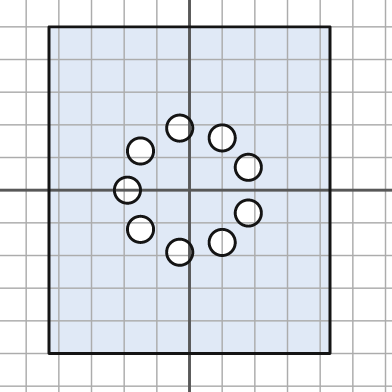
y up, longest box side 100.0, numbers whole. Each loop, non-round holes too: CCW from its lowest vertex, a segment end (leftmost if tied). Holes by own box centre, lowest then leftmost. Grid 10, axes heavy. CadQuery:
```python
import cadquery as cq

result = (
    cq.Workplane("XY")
    .moveTo(-43.0, -50.0)
    .lineTo(43.0, -50.0)
    .lineTo(43.0, 50.0)
    .lineTo(-43.0, 50.0)
    .close()
    .moveTo(-3.0, -19.0)
    .circle(4.0)
    .moveTo(10.0, -16.0)
    .circle(4.0)
    .moveTo(-15.0, -12.0)
    .circle(4.0)
    .moveTo(18.0, -7.0)
    .circle(4.0)
    .moveTo(-19.0, 0.0)
    .circle(4.0)
    .moveTo(18.0, 7.0)
    .circle(4.0)
    .moveTo(-15.0, 12.0)
    .circle(4.0)
    .moveTo(10.0, 16.0)
    .circle(4.0)
    .moveTo(-3.0, 19.0)
    .circle(4.0)
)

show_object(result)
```